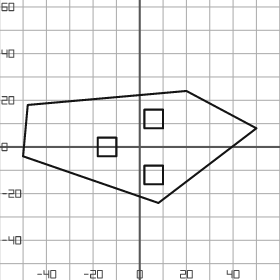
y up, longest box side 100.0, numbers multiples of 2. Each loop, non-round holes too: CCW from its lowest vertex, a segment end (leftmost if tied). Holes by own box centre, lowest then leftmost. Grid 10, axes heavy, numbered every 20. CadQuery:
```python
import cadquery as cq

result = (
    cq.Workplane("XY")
    .moveTo(8.0, -24.0)
    .lineTo(50.0, 8.0)
    .lineTo(20.0, 24.0)
    .lineTo(-48.0, 18.0)
    .lineTo(-50.0, -4.0)
    .close()
    .moveTo(2.0, -16.0)
    .lineTo(10.0, -16.0)
    .lineTo(10.0, -8.0)
    .lineTo(2.0, -8.0)
    .close()
    .moveTo(-18.0, -4.0)
    .lineTo(-10.0, -4.0)
    .lineTo(-10.0, 4.0)
    .lineTo(-18.0, 4.0)
    .close()
    .moveTo(2.0, 8.0)
    .lineTo(10.0, 8.0)
    .lineTo(10.0, 16.0)
    .lineTo(2.0, 16.0)
    .close()
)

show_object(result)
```